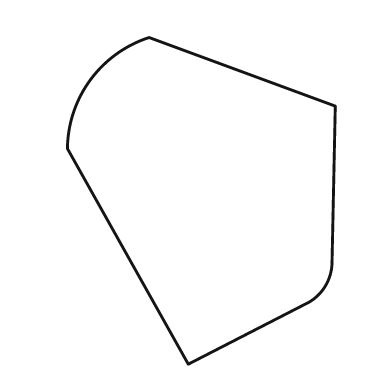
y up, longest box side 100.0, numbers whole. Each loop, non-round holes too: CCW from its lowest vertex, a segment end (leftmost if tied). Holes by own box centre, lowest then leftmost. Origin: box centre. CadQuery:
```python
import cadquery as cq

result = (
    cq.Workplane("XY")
    .moveTo(-4.0, -50.0)
    .lineTo(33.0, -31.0)
    .threePointArc((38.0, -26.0), (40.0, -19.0))
    .lineTo(41.0, 29.0)
    .lineTo(-16.0, 50.0)
    .threePointArc((-34.0, 37.0), (-41.0, 16.0))
    .close()
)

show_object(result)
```